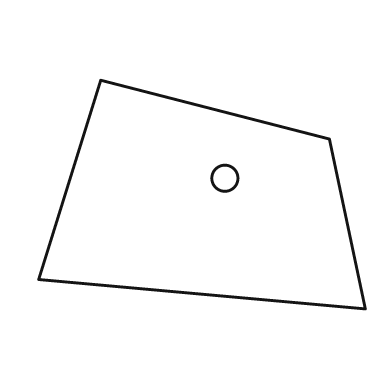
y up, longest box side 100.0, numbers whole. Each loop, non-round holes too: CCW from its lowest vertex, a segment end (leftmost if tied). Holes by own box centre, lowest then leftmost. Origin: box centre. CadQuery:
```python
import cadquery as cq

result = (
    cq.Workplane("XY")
    .moveTo(50.0, -35.0)
    .lineTo(39.0, 17.0)
    .lineTo(-31.0, 35.0)
    .lineTo(-50.0, -26.0)
    .close()
    .moveTo(7.0, 5.0)
    .circle(4.0)
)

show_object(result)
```